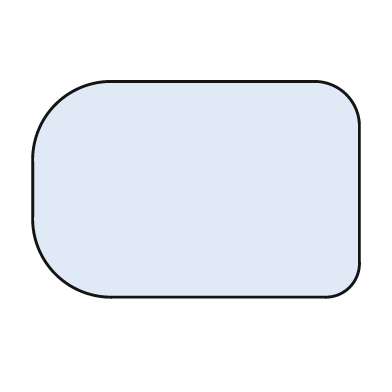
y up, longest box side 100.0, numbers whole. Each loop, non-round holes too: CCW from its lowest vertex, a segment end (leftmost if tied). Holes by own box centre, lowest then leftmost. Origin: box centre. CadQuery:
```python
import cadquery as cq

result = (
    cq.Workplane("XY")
    .moveTo(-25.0, -33.0)
    .lineTo(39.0, -33.0)
    .threePointArc((47.0, -30.0), (50.0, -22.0))
    .lineTo(50.0, 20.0)
    .threePointArc((46.0, 29.0), (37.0, 33.0))
    .lineTo(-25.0, 33.0)
    .threePointArc((-43.0, 26.0), (-50.0, 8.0))
    .lineTo(-50.0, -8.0)
    .threePointArc((-43.0, -26.0), (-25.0, -33.0))
    .close()
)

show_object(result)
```